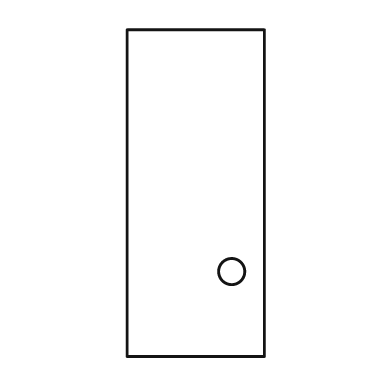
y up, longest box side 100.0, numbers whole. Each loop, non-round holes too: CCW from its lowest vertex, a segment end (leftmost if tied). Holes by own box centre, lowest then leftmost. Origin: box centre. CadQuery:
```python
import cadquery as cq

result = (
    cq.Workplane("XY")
    .moveTo(-21.0, -50.0)
    .lineTo(21.0, -50.0)
    .lineTo(21.0, 50.0)
    .lineTo(-21.0, 50.0)
    .close()
    .moveTo(11.0, -24.0)
    .circle(4.0)
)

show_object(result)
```